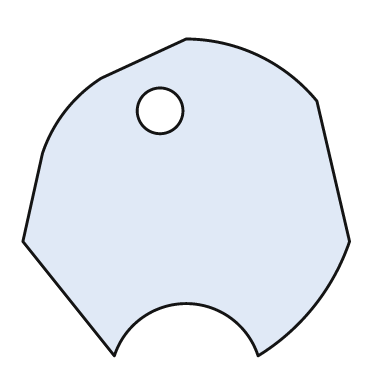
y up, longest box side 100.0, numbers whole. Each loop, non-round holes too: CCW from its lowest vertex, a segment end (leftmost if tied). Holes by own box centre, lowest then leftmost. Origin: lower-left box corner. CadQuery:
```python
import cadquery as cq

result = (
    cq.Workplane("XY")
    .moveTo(28.0, 0.0)
    .threePointArc((50.0, 16.0), (72.0, 0.0))
    .threePointArc((89.0, 15.0), (100.0, 35.0))
    .lineTo(90.0, 78.0)
    .threePointArc((72.0, 92.0), (50.0, 97.0))
    .lineTo(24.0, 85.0)
    .threePointArc((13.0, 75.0), (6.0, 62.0))
    .lineTo(0.0, 35.0)
    .close()
    .moveTo(42.0, 75.0)
    .circle(7.0)
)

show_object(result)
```